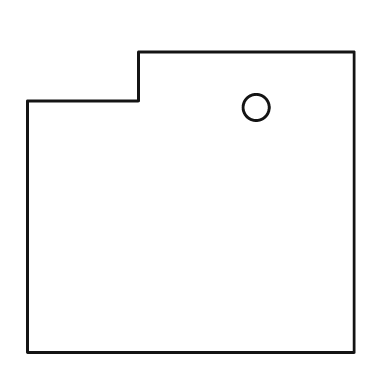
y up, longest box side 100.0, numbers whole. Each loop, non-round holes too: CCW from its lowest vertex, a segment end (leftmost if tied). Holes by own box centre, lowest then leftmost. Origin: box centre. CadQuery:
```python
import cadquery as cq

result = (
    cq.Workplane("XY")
    .moveTo(-50.0, -46.0)
    .lineTo(50.0, -46.0)
    .lineTo(50.0, 46.0)
    .lineTo(-16.0, 46.0)
    .lineTo(-16.0, 31.0)
    .lineTo(-50.0, 31.0)
    .close()
    .moveTo(20.0, 29.0)
    .circle(4.0)
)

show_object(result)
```